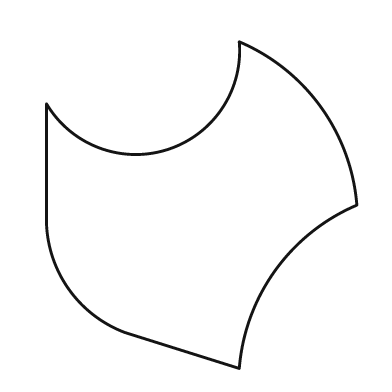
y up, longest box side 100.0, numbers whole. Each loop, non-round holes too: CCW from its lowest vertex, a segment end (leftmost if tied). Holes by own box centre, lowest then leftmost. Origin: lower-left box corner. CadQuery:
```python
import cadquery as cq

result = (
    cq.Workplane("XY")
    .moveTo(59.0, 0.0)
    .threePointArc((70.0, 30.0), (95.0, 50.0))
    .threePointArc((84.0, 80.0), (59.0, 100.0))
    .threePointArc((37.0, 67.0), (0.0, 81.0))
    .lineTo(0.0, 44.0)
    .threePointArc((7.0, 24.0), (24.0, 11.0))
    .close()
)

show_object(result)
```